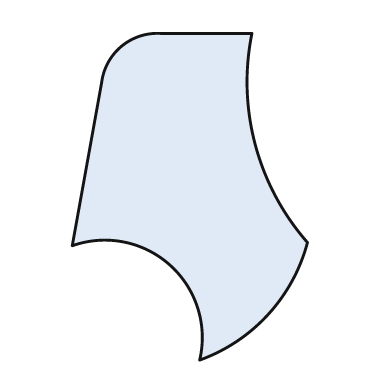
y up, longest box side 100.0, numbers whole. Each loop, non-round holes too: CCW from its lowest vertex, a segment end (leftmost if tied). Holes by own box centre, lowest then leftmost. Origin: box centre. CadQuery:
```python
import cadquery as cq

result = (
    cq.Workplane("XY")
    .moveTo(3.0, -50.0)
    .threePointArc((24.0, -36.0), (36.0, -14.0))
    .threePointArc((20.0, 16.0), (19.0, 50.0))
    .lineTo(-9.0, 50.0)
    .threePointArc((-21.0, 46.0), (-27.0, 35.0))
    .lineTo(-36.0, -15.0)
    .threePointArc((-6.0, -21.0), (3.0, -50.0))
    .close()
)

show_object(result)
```